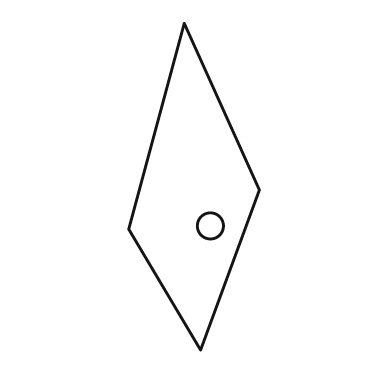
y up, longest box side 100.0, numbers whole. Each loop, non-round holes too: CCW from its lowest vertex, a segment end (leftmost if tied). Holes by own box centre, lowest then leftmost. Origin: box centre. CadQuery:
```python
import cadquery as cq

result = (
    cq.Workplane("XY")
    .moveTo(2.0, -50.0)
    .lineTo(20.0, -1.0)
    .lineTo(-3.0, 50.0)
    .lineTo(-20.0, -13.0)
    .close()
    .moveTo(5.0, -12.0)
    .circle(4.0)
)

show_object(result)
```